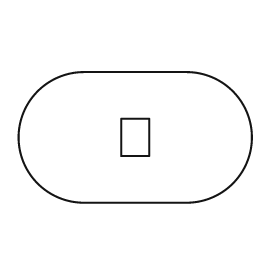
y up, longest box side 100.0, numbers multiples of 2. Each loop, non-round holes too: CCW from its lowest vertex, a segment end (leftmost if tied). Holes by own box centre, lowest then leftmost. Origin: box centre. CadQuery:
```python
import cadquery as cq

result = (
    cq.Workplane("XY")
    .moveTo(-22.0, -28.0)
    .lineTo(22.0, -28.0)
    .threePointArc((50.0, 0.0), (22.0, 28.0))
    .lineTo(-22.0, 28.0)
    .threePointArc((-50.0, 0.0), (-22.0, -28.0))
    .close()
    .moveTo(-6.0, -8.0)
    .lineTo(6.0, -8.0)
    .lineTo(6.0, 8.0)
    .lineTo(-6.0, 8.0)
    .close()
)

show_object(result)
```